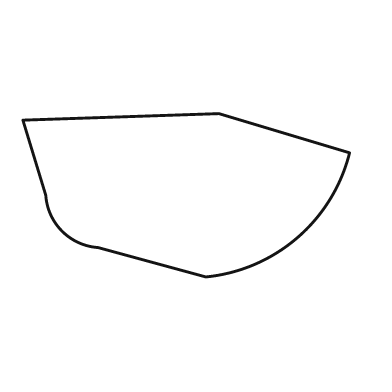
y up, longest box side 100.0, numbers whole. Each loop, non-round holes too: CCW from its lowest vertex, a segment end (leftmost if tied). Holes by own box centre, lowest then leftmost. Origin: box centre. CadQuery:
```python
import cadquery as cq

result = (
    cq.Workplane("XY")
    .moveTo(6.0, -25.0)
    .threePointArc((34.0, -13.0), (50.0, 13.0))
    .lineTo(10.0, 25.0)
    .lineTo(-50.0, 23.0)
    .lineTo(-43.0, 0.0)
    .threePointArc((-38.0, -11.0), (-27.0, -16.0))
    .close()
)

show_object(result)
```